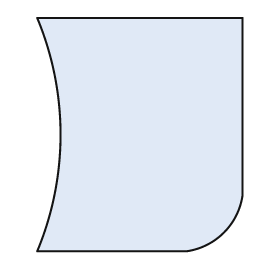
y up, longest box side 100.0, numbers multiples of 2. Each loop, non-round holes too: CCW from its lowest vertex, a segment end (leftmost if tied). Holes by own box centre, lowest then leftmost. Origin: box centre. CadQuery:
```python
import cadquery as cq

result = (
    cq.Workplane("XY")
    .moveTo(-44.0, -50.0)
    .lineTo(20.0, -50.0)
    .threePointArc((36.0, -42.0), (44.0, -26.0))
    .lineTo(44.0, 50.0)
    .lineTo(-44.0, 50.0)
    .threePointArc((-34.0, 0.0), (-44.0, -50.0))
    .close()
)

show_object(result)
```